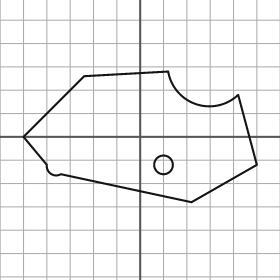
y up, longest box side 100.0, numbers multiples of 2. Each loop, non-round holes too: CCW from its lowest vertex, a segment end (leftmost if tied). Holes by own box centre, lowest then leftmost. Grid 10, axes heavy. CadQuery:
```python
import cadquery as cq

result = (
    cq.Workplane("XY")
    .moveTo(22.0, -28.0)
    .lineTo(50.0, -12.0)
    .lineTo(42.0, 18.0)
    .threePointArc((24.0, 14.0), (12.0, 28.0))
    .lineTo(-24.0, 26.0)
    .lineTo(-50.0, 0.0)
    .lineTo(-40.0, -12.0)
    .threePointArc((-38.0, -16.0), (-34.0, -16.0))
    .close()
    .moveTo(10.0, -12.0)
    .circle(4.0)
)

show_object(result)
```